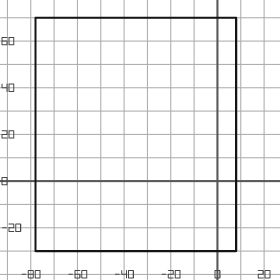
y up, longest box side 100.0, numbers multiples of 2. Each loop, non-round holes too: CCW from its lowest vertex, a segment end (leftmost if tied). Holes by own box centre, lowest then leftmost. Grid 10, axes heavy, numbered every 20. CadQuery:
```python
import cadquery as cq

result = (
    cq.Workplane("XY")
    .moveTo(-78.0, -30.0)
    .lineTo(8.0, -30.0)
    .lineTo(8.0, 70.0)
    .lineTo(-78.0, 70.0)
    .close()
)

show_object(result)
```